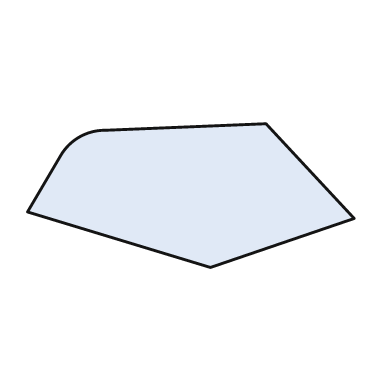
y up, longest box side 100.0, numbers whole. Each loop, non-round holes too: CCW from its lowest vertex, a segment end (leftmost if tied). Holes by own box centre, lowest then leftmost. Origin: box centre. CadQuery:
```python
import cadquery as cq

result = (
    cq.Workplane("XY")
    .moveTo(6.0, -22.0)
    .lineTo(50.0, -7.0)
    .lineTo(23.0, 22.0)
    .lineTo(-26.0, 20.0)
    .threePointArc((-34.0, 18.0), (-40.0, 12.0))
    .lineTo(-50.0, -5.0)
    .close()
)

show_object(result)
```